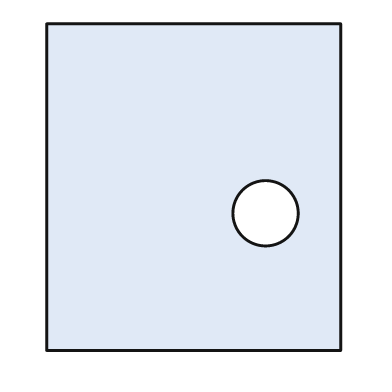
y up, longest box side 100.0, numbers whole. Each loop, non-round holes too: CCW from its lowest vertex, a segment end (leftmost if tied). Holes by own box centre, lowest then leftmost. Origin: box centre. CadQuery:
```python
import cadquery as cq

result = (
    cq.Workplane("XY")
    .moveTo(-45.0, -50.0)
    .lineTo(45.0, -50.0)
    .lineTo(45.0, 50.0)
    .lineTo(-45.0, 50.0)
    .close()
    .moveTo(22.0, -8.0)
    .circle(10.0)
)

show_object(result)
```